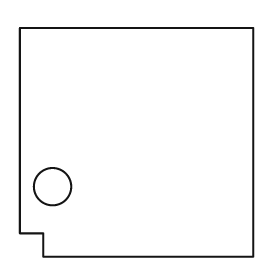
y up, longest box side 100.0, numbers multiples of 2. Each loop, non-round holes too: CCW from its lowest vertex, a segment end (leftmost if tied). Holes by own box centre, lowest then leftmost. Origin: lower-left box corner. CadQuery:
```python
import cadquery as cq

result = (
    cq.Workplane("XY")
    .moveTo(10.0, 0.0)
    .lineTo(100.0, 0.0)
    .lineTo(100.0, 98.0)
    .lineTo(0.0, 98.0)
    .lineTo(0.0, 10.0)
    .lineTo(10.0, 10.0)
    .close()
    .moveTo(14.0, 30.0)
    .circle(8.0)
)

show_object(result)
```